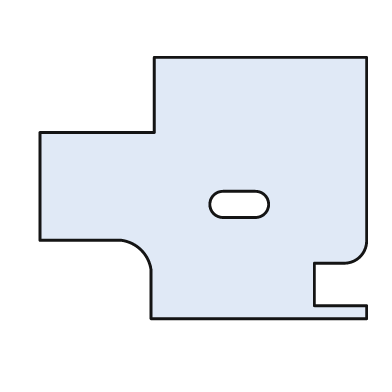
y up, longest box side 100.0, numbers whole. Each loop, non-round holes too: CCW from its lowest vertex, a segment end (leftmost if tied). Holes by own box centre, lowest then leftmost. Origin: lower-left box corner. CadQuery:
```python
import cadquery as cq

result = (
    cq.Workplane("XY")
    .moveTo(34.0, 0.0)
    .lineTo(100.0, 0.0)
    .lineTo(100.0, 4.0)
    .lineTo(84.0, 4.0)
    .lineTo(84.0, 17.0)
    .lineTo(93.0, 17.0)
    .threePointArc((98.0, 19.0), (100.0, 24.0))
    .lineTo(100.0, 80.0)
    .lineTo(35.0, 80.0)
    .lineTo(35.0, 57.0)
    .lineTo(0.0, 57.0)
    .lineTo(0.0, 24.0)
    .lineTo(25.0, 24.0)
    .threePointArc((31.0, 21.0), (34.0, 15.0))
    .close()
    .moveTo(56.0, 31.0)
    .lineTo(66.0, 31.0)
    .threePointArc((70.0, 35.0), (66.0, 39.0))
    .lineTo(56.0, 39.0)
    .threePointArc((52.0, 35.0), (56.0, 31.0))
    .close()
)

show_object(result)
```